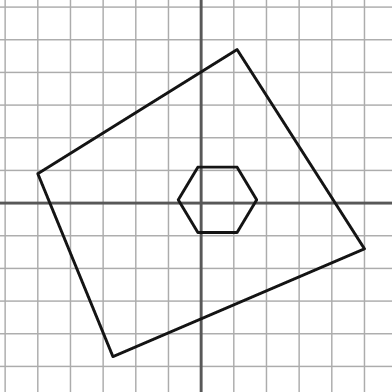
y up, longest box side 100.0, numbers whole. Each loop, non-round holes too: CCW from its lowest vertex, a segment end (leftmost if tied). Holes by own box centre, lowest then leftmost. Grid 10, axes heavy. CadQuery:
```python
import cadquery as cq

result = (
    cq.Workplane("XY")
    .moveTo(-27.0, -47.0)
    .lineTo(50.0, -14.0)
    .lineTo(11.0, 47.0)
    .lineTo(-50.0, 9.0)
    .close()
    .moveTo(-1.0, -9.0)
    .lineTo(11.0, -9.0)
    .lineTo(17.0, 1.0)
    .lineTo(11.0, 11.0)
    .lineTo(-1.0, 11.0)
    .lineTo(-7.0, 1.0)
    .close()
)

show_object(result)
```